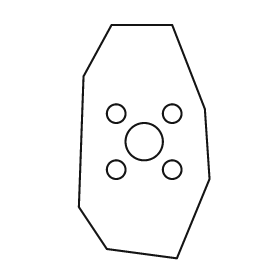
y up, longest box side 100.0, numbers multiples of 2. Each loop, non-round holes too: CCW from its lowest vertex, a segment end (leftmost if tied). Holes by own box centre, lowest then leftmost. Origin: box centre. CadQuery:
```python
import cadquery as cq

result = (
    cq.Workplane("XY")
    .moveTo(14.0, -50.0)
    .lineTo(28.0, -16.0)
    .lineTo(26.0, 14.0)
    .lineTo(12.0, 50.0)
    .lineTo(-14.0, 50.0)
    .lineTo(-26.0, 28.0)
    .lineTo(-28.0, -28.0)
    .lineTo(-16.0, -46.0)
    .close()
    .moveTo(-12.0, -12.0)
    .circle(4.0)
    .moveTo(12.0, -12.0)
    .circle(4.0)
    .moveTo(0.0, 0.0)
    .circle(8.0)
    .moveTo(-12.0, 12.0)
    .circle(4.0)
    .moveTo(12.0, 12.0)
    .circle(4.0)
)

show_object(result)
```